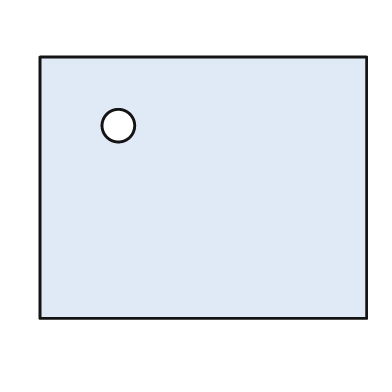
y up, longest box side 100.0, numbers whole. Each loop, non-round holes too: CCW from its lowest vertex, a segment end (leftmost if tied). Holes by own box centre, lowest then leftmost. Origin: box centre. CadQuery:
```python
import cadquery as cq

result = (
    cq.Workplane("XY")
    .moveTo(-50.0, -40.0)
    .lineTo(50.0, -40.0)
    .lineTo(50.0, 40.0)
    .lineTo(-50.0, 40.0)
    .close()
    .moveTo(-26.0, 19.0)
    .circle(5.0)
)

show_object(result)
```